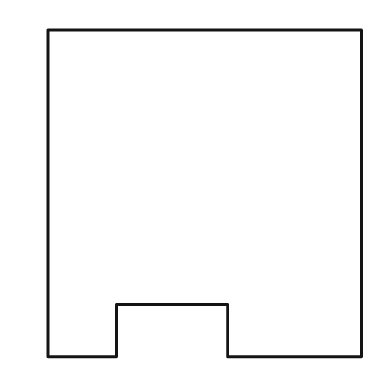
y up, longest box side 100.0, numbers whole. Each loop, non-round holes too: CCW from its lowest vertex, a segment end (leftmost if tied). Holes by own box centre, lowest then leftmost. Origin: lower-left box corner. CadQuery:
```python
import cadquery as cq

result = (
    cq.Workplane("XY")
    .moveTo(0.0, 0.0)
    .lineTo(21.0, 0.0)
    .lineTo(21.0, 16.0)
    .lineTo(55.0, 16.0)
    .lineTo(55.0, 0.0)
    .lineTo(96.0, 0.0)
    .lineTo(96.0, 100.0)
    .lineTo(0.0, 100.0)
    .close()
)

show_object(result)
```